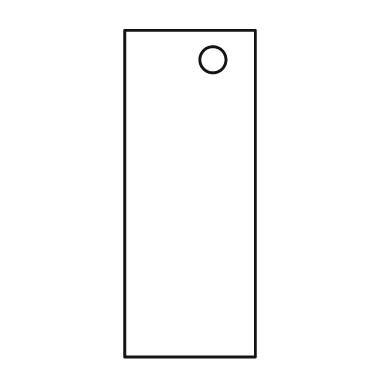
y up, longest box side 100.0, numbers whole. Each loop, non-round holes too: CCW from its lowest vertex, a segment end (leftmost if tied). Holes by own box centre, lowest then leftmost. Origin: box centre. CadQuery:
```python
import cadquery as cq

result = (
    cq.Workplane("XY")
    .moveTo(-20.0, -50.0)
    .lineTo(20.0, -50.0)
    .lineTo(20.0, 50.0)
    .lineTo(-20.0, 50.0)
    .close()
    .moveTo(7.0, 41.0)
    .circle(4.0)
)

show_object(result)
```